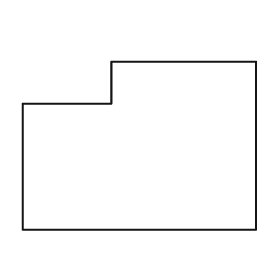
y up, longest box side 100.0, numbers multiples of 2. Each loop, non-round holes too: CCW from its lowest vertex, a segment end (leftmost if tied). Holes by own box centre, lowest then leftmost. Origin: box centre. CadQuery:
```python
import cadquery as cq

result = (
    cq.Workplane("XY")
    .moveTo(-50.0, -36.0)
    .lineTo(50.0, -36.0)
    .lineTo(50.0, 36.0)
    .lineTo(-12.0, 36.0)
    .lineTo(-12.0, 18.0)
    .lineTo(-50.0, 18.0)
    .close()
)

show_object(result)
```